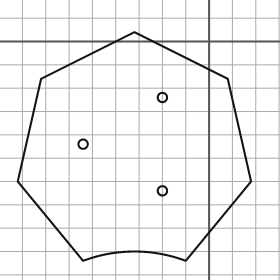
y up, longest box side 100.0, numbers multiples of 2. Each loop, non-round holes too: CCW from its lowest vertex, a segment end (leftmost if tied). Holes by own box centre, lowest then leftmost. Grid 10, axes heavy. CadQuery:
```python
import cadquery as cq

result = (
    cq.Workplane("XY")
    .moveTo(-54.0, -94.0)
    .threePointArc((-32.0, -90.0), (-10.0, -94.0))
    .lineTo(18.0, -60.0)
    .lineTo(8.0, -16.0)
    .lineTo(-32.0, 4.0)
    .lineTo(-72.0, -16.0)
    .lineTo(-82.0, -60.0)
    .close()
    .moveTo(-20.0, -64.0)
    .circle(2.0)
    .moveTo(-54.0, -44.0)
    .circle(2.0)
    .moveTo(-20.0, -24.0)
    .circle(2.0)
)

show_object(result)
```